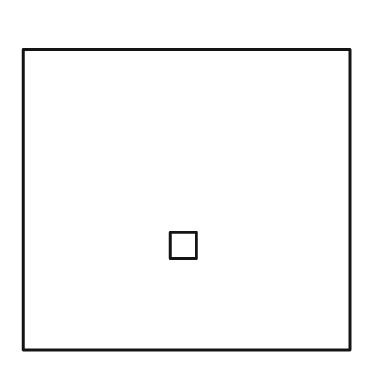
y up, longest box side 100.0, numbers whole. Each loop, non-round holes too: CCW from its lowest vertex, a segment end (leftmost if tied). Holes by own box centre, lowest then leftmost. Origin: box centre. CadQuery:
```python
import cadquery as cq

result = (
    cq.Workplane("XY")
    .moveTo(-50.0, -46.0)
    .lineTo(50.0, -46.0)
    .lineTo(50.0, 46.0)
    .lineTo(-50.0, 46.0)
    .close()
    .moveTo(-5.0, -18.0)
    .lineTo(3.0, -18.0)
    .lineTo(3.0, -10.0)
    .lineTo(-5.0, -10.0)
    .close()
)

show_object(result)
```